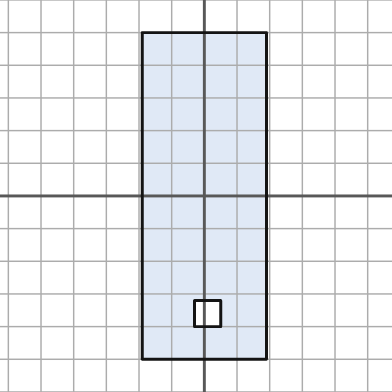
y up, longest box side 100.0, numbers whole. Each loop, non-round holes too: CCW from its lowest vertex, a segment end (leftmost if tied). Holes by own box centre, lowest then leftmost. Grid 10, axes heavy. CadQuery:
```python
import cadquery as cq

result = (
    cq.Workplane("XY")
    .moveTo(-19.0, -50.0)
    .lineTo(19.0, -50.0)
    .lineTo(19.0, 50.0)
    .lineTo(-19.0, 50.0)
    .close()
    .moveTo(-3.0, -40.0)
    .lineTo(5.0, -40.0)
    .lineTo(5.0, -32.0)
    .lineTo(-3.0, -32.0)
    .close()
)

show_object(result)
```